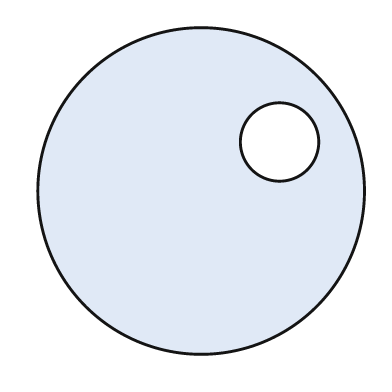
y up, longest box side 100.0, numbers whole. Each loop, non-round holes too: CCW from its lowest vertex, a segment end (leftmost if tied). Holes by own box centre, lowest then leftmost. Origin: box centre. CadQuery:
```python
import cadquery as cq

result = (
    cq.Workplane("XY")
    .moveTo(0.0, 0.0)
    .circle(50.0)
    .moveTo(24.0, 15.0)
    .circle(12.0)
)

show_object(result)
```